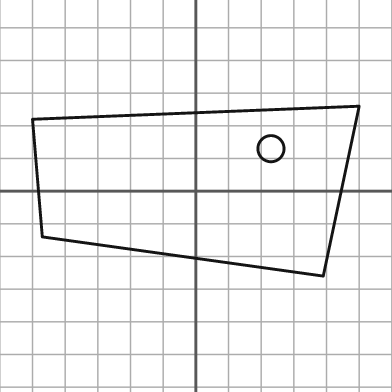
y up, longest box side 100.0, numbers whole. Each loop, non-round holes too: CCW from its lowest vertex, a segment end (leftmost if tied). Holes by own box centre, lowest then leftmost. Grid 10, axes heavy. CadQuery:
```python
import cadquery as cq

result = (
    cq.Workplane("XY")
    .moveTo(39.0, -26.0)
    .lineTo(50.0, 26.0)
    .lineTo(-50.0, 22.0)
    .lineTo(-47.0, -14.0)
    .close()
    .moveTo(23.0, 13.0)
    .circle(4.0)
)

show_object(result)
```